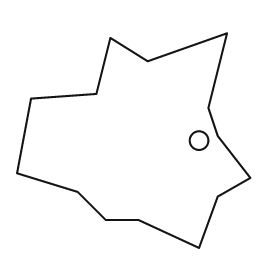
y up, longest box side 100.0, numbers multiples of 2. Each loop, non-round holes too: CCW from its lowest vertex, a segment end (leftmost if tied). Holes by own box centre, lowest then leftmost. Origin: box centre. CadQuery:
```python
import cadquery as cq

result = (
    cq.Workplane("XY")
    .moveTo(28.0, -46.0)
    .lineTo(36.0, -24.0)
    .lineTo(50.0, -16.0)
    .lineTo(36.0, 2.0)
    .lineTo(32.0, 14.0)
    .lineTo(40.0, 46.0)
    .lineTo(6.0, 34.0)
    .lineTo(-10.0, 44.0)
    .lineTo(-16.0, 20.0)
    .lineTo(-44.0, 18.0)
    .lineTo(-50.0, -14.0)
    .lineTo(-24.0, -22.0)
    .lineTo(-12.0, -34.0)
    .lineTo(2.0, -34.0)
    .close()
    .moveTo(28.0, 0.0)
    .circle(4.0)
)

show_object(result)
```